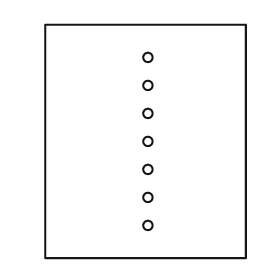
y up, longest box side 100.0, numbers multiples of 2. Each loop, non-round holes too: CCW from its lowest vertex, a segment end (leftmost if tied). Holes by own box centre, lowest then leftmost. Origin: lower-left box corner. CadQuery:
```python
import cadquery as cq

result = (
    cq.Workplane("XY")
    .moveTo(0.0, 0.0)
    .lineTo(86.0, 0.0)
    .lineTo(86.0, 100.0)
    .lineTo(0.0, 100.0)
    .close()
    .moveTo(44.0, 14.0)
    .circle(2.0)
    .moveTo(44.0, 26.0)
    .circle(2.0)
    .moveTo(44.0, 38.0)
    .circle(2.0)
    .moveTo(44.0, 50.0)
    .circle(2.0)
    .moveTo(44.0, 62.0)
    .circle(2.0)
    .moveTo(44.0, 74.0)
    .circle(2.0)
    .moveTo(44.0, 86.0)
    .circle(2.0)
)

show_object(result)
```